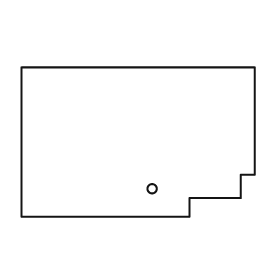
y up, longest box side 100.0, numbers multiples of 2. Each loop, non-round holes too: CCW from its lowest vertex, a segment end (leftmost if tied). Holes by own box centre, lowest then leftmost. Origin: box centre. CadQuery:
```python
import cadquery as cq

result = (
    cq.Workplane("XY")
    .moveTo(-50.0, -32.0)
    .lineTo(22.0, -32.0)
    .lineTo(22.0, -24.0)
    .lineTo(44.0, -24.0)
    .lineTo(44.0, -14.0)
    .lineTo(50.0, -14.0)
    .lineTo(50.0, 32.0)
    .lineTo(-50.0, 32.0)
    .close()
    .moveTo(6.0, -20.0)
    .circle(2.0)
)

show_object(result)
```